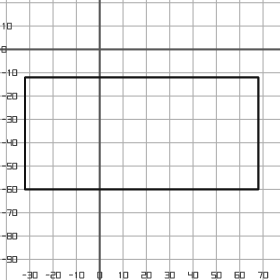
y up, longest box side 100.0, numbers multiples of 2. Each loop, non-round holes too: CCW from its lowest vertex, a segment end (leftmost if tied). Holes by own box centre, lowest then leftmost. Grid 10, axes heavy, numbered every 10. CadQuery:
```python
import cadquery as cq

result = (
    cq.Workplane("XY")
    .moveTo(-32.0, -60.0)
    .lineTo(68.0, -60.0)
    .lineTo(68.0, -12.0)
    .lineTo(-32.0, -12.0)
    .close()
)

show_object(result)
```